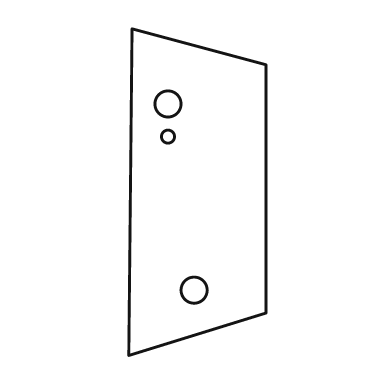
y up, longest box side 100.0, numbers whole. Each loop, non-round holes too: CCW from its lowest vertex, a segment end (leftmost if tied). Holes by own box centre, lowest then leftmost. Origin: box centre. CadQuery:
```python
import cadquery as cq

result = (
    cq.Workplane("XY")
    .moveTo(-21.0, -50.0)
    .lineTo(21.0, -37.0)
    .lineTo(21.0, 39.0)
    .lineTo(-20.0, 50.0)
    .close()
    .moveTo(-1.0, -30.0)
    .circle(4.0)
    .moveTo(-9.0, 17.0)
    .circle(2.0)
    .moveTo(-9.0, 27.0)
    .circle(4.0)
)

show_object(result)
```